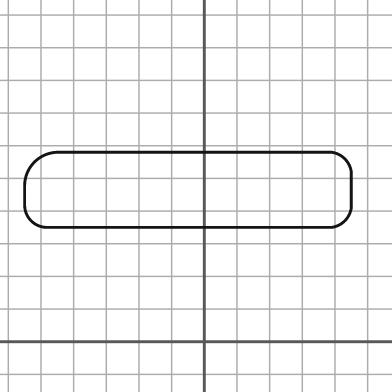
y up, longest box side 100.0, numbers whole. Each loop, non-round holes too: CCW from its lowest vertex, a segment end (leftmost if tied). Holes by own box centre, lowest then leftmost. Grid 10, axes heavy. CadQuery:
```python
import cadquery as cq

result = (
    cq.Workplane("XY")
    .moveTo(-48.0, 35.0)
    .lineTo(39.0, 35.0)
    .threePointArc((43.0, 37.0), (45.0, 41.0))
    .lineTo(45.0, 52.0)
    .threePointArc((43.0, 56.0), (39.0, 58.0))
    .lineTo(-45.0, 58.0)
    .threePointArc((-52.0, 55.0), (-55.0, 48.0))
    .lineTo(-55.0, 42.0)
    .threePointArc((-53.0, 37.0), (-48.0, 35.0))
    .close()
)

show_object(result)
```